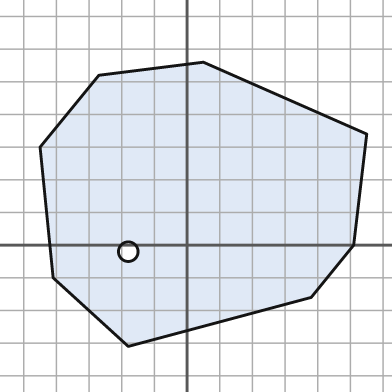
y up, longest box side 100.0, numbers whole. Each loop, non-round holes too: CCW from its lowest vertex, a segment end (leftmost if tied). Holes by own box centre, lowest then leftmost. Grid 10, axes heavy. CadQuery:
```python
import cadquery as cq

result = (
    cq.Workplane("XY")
    .moveTo(-18.0, -31.0)
    .lineTo(38.0, -16.0)
    .lineTo(51.0, 0.0)
    .lineTo(55.0, 34.0)
    .lineTo(5.0, 56.0)
    .lineTo(-27.0, 52.0)
    .lineTo(-45.0, 30.0)
    .lineTo(-41.0, -10.0)
    .close()
    .moveTo(-18.0, -2.0)
    .circle(3.0)
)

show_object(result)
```